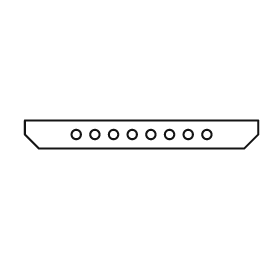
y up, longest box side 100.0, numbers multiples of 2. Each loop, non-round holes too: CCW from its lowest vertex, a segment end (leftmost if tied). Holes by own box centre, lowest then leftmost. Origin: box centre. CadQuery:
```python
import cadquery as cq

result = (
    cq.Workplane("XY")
    .moveTo(-44.0, -6.0)
    .lineTo(44.0, -6.0)
    .lineTo(50.0, 0.0)
    .lineTo(50.0, 6.0)
    .lineTo(-50.0, 6.0)
    .lineTo(-50.0, 0.0)
    .close()
    .moveTo(-28.0, 0.0)
    .circle(2.0)
    .moveTo(-20.0, 0.0)
    .circle(2.0)
    .moveTo(-12.0, 0.0)
    .circle(2.0)
    .moveTo(-4.0, 0.0)
    .circle(2.0)
    .moveTo(4.0, 0.0)
    .circle(2.0)
    .moveTo(12.0, 0.0)
    .circle(2.0)
    .moveTo(20.0, 0.0)
    .circle(2.0)
    .moveTo(28.0, 0.0)
    .circle(2.0)
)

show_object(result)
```